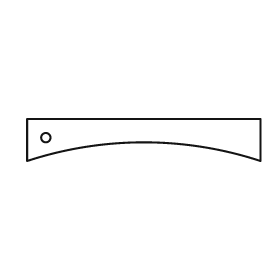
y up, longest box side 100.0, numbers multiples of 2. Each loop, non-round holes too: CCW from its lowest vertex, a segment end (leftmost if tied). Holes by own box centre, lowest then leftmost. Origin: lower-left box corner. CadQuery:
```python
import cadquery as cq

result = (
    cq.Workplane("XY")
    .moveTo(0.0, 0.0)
    .threePointArc((50.0, 8.0), (100.0, 0.0))
    .lineTo(100.0, 18.0)
    .lineTo(0.0, 18.0)
    .close()
    .moveTo(8.0, 10.0)
    .circle(2.0)
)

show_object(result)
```